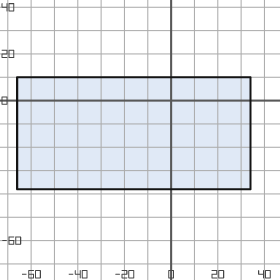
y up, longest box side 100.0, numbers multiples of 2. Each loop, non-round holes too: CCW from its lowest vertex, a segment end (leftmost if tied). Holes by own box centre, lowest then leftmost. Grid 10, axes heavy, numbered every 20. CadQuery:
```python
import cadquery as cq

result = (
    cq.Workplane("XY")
    .moveTo(-66.0, -38.0)
    .lineTo(34.0, -38.0)
    .lineTo(34.0, 10.0)
    .lineTo(-66.0, 10.0)
    .close()
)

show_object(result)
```